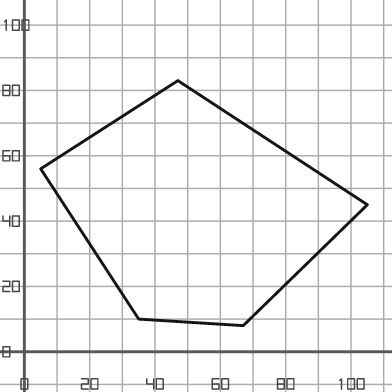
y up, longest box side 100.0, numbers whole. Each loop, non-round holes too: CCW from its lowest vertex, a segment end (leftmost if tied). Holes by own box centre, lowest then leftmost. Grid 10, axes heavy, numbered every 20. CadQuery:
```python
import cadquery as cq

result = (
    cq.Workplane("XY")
    .moveTo(67.0, 8.0)
    .lineTo(105.0, 45.0)
    .lineTo(47.0, 83.0)
    .lineTo(5.0, 56.0)
    .lineTo(35.0, 10.0)
    .close()
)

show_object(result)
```